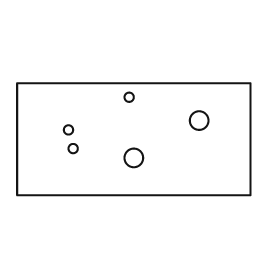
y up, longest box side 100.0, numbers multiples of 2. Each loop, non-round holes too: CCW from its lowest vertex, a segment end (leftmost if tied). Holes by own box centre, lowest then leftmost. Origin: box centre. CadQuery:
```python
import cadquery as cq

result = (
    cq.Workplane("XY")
    .moveTo(-50.0, -24.0)
    .lineTo(50.0, -24.0)
    .lineTo(50.0, 24.0)
    .lineTo(-50.0, 24.0)
    .close()
    .moveTo(0.0, -8.0)
    .circle(4.0)
    .moveTo(-26.0, -4.0)
    .circle(2.0)
    .moveTo(-28.0, 4.0)
    .circle(2.0)
    .moveTo(28.0, 8.0)
    .circle(4.0)
    .moveTo(-2.0, 18.0)
    .circle(2.0)
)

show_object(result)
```